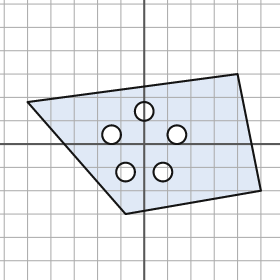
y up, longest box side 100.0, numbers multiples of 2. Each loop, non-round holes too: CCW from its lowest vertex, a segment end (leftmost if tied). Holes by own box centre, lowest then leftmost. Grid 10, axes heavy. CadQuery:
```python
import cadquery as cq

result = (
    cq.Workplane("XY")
    .moveTo(-8.0, -30.0)
    .lineTo(50.0, -20.0)
    .lineTo(40.0, 30.0)
    .lineTo(-50.0, 18.0)
    .close()
    .moveTo(-8.0, -12.0)
    .circle(4.0)
    .moveTo(8.0, -12.0)
    .circle(4.0)
    .moveTo(-14.0, 4.0)
    .circle(4.0)
    .moveTo(14.0, 4.0)
    .circle(4.0)
    .moveTo(0.0, 14.0)
    .circle(4.0)
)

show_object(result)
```